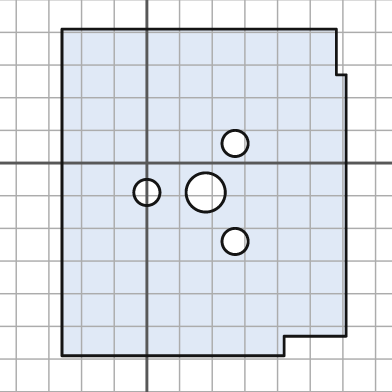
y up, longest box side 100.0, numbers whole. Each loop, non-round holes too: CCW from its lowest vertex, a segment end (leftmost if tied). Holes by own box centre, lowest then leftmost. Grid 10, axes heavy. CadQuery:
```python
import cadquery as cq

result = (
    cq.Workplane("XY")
    .moveTo(-26.0, -59.0)
    .lineTo(42.0, -59.0)
    .lineTo(42.0, -53.0)
    .lineTo(61.0, -53.0)
    .lineTo(61.0, 27.0)
    .lineTo(58.0, 27.0)
    .lineTo(58.0, 41.0)
    .lineTo(-26.0, 41.0)
    .close()
    .moveTo(27.0, -24.0)
    .circle(4.0)
    .moveTo(0.0, -9.0)
    .circle(4.0)
    .moveTo(18.0, -9.0)
    .circle(6.0)
    .moveTo(27.0, 6.0)
    .circle(4.0)
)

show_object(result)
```